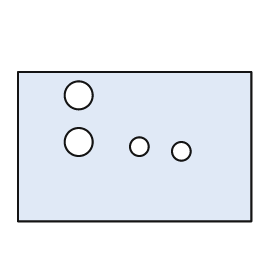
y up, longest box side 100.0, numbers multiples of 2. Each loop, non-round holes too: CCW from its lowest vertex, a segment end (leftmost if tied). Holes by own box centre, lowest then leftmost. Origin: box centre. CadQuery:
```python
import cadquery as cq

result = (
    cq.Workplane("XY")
    .moveTo(-50.0, -32.0)
    .lineTo(50.0, -32.0)
    .lineTo(50.0, 32.0)
    .lineTo(-50.0, 32.0)
    .close()
    .moveTo(20.0, -2.0)
    .circle(4.0)
    .moveTo(2.0, 0.0)
    .circle(4.0)
    .moveTo(-24.0, 2.0)
    .circle(6.0)
    .moveTo(-24.0, 22.0)
    .circle(6.0)
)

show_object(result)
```